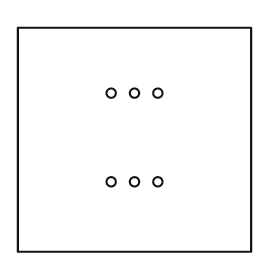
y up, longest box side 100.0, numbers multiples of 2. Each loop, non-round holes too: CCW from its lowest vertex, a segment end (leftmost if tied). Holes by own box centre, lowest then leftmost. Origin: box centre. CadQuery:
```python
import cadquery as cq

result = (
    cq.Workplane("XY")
    .moveTo(-50.0, -48.0)
    .lineTo(50.0, -48.0)
    .lineTo(50.0, 48.0)
    .lineTo(-50.0, 48.0)
    .close()
    .moveTo(-10.0, -18.0)
    .circle(2.0)
    .moveTo(0.0, -18.0)
    .circle(2.0)
    .moveTo(10.0, -18.0)
    .circle(2.0)
    .moveTo(-10.0, 20.0)
    .circle(2.0)
    .moveTo(0.0, 20.0)
    .circle(2.0)
    .moveTo(10.0, 20.0)
    .circle(2.0)
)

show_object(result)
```